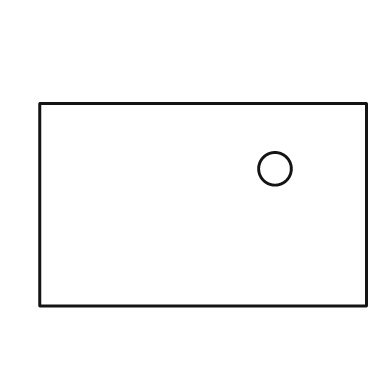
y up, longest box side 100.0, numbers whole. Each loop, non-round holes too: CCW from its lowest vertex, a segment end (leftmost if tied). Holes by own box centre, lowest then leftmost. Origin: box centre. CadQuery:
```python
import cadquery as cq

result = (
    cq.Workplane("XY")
    .moveTo(-50.0, -31.0)
    .lineTo(50.0, -31.0)
    .lineTo(50.0, 31.0)
    .lineTo(-50.0, 31.0)
    .close()
    .moveTo(22.0, 11.0)
    .circle(5.0)
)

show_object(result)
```